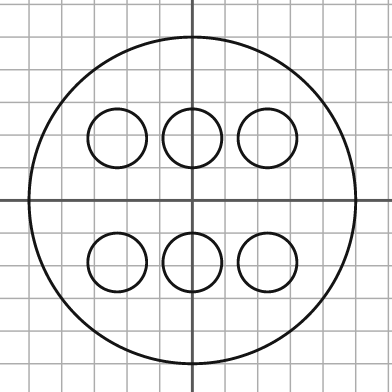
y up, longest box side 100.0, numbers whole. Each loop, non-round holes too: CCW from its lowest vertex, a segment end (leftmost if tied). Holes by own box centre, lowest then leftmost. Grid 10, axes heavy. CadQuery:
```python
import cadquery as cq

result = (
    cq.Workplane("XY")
    .moveTo(0.0, 0.0)
    .circle(50.0)
    .moveTo(-23.0, -19.0)
    .circle(9.0)
    .moveTo(0.0, -19.0)
    .circle(9.0)
    .moveTo(23.0, -19.0)
    .circle(9.0)
    .moveTo(-23.0, 19.0)
    .circle(9.0)
    .moveTo(0.0, 19.0)
    .circle(9.0)
    .moveTo(23.0, 19.0)
    .circle(9.0)
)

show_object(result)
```